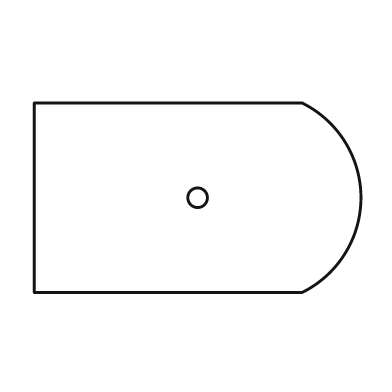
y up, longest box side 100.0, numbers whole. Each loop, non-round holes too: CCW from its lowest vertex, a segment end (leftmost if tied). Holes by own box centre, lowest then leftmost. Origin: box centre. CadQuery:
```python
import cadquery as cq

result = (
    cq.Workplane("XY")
    .moveTo(-50.0, -29.0)
    .lineTo(32.0, -29.0)
    .threePointArc((50.0, 0.0), (32.0, 29.0))
    .lineTo(-50.0, 29.0)
    .close()
    .moveTo(0.0, 0.0)
    .circle(3.0)
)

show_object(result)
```